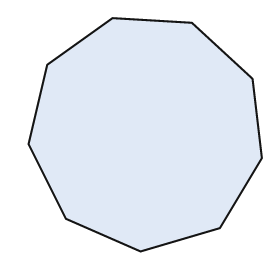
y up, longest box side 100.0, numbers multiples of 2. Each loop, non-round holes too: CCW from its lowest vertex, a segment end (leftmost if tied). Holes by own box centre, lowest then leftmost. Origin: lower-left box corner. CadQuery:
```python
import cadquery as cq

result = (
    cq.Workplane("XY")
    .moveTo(48.0, 0.0)
    .lineTo(82.0, 10.0)
    .lineTo(100.0, 40.0)
    .lineTo(96.0, 74.0)
    .lineTo(70.0, 98.0)
    .lineTo(36.0, 100.0)
    .lineTo(8.0, 80.0)
    .lineTo(0.0, 46.0)
    .lineTo(16.0, 14.0)
    .close()
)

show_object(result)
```